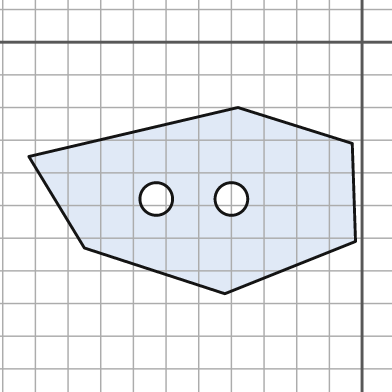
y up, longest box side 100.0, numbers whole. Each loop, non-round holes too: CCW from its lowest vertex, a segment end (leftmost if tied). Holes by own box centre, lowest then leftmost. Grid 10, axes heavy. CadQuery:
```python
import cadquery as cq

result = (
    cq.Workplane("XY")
    .moveTo(-42.0, -77.0)
    .lineTo(-2.0, -61.0)
    .lineTo(-3.0, -31.0)
    .lineTo(-38.0, -20.0)
    .lineTo(-102.0, -35.0)
    .lineTo(-85.0, -63.0)
    .close()
    .moveTo(-63.0, -48.0)
    .circle(5.0)
    .moveTo(-40.0, -48.0)
    .circle(5.0)
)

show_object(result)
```